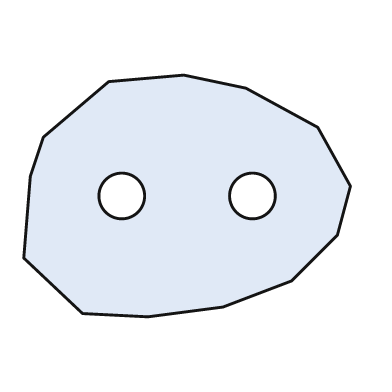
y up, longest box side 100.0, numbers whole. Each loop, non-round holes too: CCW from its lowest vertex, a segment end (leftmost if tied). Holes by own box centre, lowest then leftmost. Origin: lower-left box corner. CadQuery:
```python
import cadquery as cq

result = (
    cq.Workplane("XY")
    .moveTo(38.0, 0.0)
    .lineTo(61.0, 3.0)
    .lineTo(82.0, 11.0)
    .lineTo(96.0, 25.0)
    .lineTo(100.0, 40.0)
    .lineTo(90.0, 58.0)
    .lineTo(68.0, 70.0)
    .lineTo(49.0, 74.0)
    .lineTo(26.0, 72.0)
    .lineTo(6.0, 55.0)
    .lineTo(2.0, 43.0)
    .lineTo(0.0, 18.0)
    .lineTo(18.0, 1.0)
    .close()
    .moveTo(30.0, 37.0)
    .circle(7.0)
    .moveTo(70.0, 37.0)
    .circle(7.0)
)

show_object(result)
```